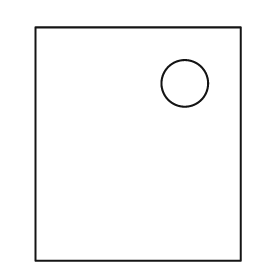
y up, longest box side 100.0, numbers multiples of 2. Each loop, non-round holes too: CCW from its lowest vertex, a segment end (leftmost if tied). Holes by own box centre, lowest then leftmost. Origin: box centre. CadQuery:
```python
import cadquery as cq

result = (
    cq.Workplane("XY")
    .moveTo(-44.0, -50.0)
    .lineTo(44.0, -50.0)
    .lineTo(44.0, 50.0)
    .lineTo(-44.0, 50.0)
    .close()
    .moveTo(20.0, 26.0)
    .circle(10.0)
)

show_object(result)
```